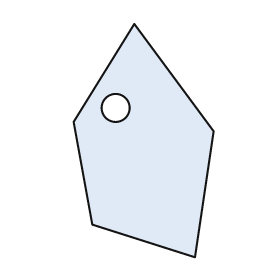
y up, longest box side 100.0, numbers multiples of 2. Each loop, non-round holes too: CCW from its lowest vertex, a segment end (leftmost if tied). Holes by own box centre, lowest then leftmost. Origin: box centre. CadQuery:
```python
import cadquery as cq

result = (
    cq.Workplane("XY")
    .moveTo(22.0, -50.0)
    .lineTo(30.0, 4.0)
    .lineTo(-4.0, 50.0)
    .lineTo(-30.0, 8.0)
    .lineTo(-22.0, -36.0)
    .close()
    .moveTo(-12.0, 14.0)
    .circle(6.0)
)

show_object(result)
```